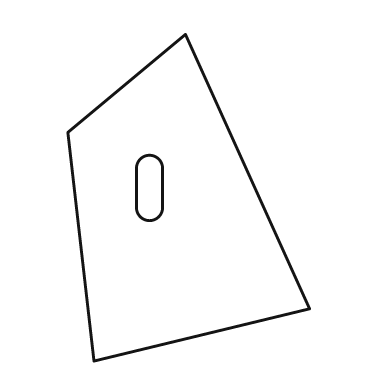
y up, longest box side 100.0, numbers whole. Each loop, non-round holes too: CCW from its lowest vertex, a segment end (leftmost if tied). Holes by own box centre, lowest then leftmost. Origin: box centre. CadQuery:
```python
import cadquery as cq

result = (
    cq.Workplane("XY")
    .moveTo(-29.0, -50.0)
    .lineTo(37.0, -34.0)
    .lineTo(-1.0, 50.0)
    .lineTo(-37.0, 20.0)
    .close()
    .moveTo(-16.0, -3.0)
    .threePointArc((-12.0, -7.0), (-8.0, -3.0))
    .lineTo(-8.0, 9.0)
    .threePointArc((-12.0, 13.0), (-16.0, 9.0))
    .close()
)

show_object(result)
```